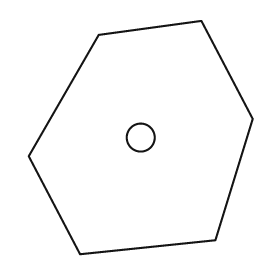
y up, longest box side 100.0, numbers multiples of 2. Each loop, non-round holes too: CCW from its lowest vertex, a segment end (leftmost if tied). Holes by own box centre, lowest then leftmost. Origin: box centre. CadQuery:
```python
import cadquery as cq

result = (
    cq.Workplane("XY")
    .moveTo(-26.0, -50.0)
    .lineTo(32.0, -44.0)
    .lineTo(48.0, 8.0)
    .lineTo(26.0, 50.0)
    .lineTo(-18.0, 44.0)
    .lineTo(-48.0, -8.0)
    .close()
    .moveTo(0.0, 0.0)
    .circle(6.0)
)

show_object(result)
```